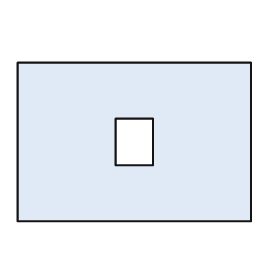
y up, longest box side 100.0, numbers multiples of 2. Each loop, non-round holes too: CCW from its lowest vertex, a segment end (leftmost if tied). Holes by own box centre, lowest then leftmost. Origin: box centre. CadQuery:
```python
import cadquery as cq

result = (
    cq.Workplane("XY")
    .moveTo(-50.0, -34.0)
    .lineTo(50.0, -34.0)
    .lineTo(50.0, 34.0)
    .lineTo(-50.0, 34.0)
    .close()
    .moveTo(-8.0, -10.0)
    .lineTo(8.0, -10.0)
    .lineTo(8.0, 10.0)
    .lineTo(-8.0, 10.0)
    .close()
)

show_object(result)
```